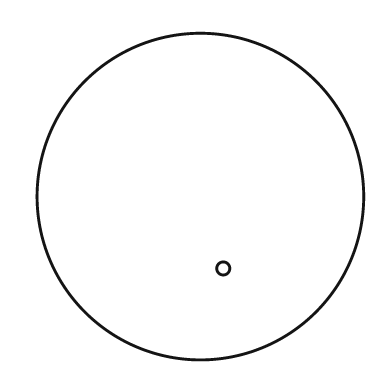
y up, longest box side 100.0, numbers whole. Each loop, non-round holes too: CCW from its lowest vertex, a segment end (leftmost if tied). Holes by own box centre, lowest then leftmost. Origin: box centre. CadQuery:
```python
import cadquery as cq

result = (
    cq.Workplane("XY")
    .moveTo(0.0, 0.0)
    .circle(50.0)
    .moveTo(7.0, -22.0)
    .circle(2.0)
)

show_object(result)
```